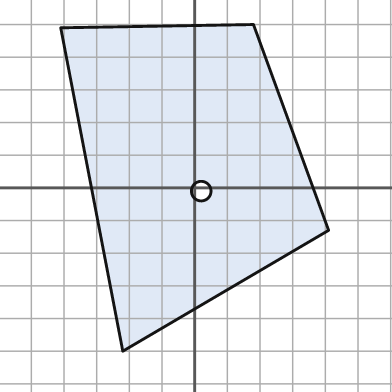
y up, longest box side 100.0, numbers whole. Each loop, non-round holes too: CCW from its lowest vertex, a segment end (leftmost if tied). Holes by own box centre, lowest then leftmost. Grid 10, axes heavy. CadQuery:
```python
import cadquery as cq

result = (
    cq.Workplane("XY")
    .moveTo(-22.0, -50.0)
    .lineTo(41.0, -13.0)
    .lineTo(18.0, 50.0)
    .lineTo(-41.0, 49.0)
    .close()
    .moveTo(2.0, -1.0)
    .circle(3.0)
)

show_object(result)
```